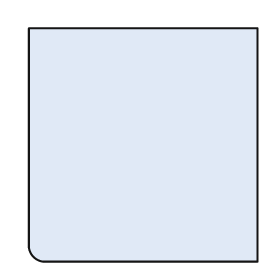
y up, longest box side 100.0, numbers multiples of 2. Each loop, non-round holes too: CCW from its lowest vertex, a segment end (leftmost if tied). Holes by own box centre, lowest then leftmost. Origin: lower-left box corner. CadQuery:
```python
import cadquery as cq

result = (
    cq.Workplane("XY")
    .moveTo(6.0, 0.0)
    .lineTo(98.0, 0.0)
    .lineTo(98.0, 100.0)
    .lineTo(0.0, 100.0)
    .lineTo(0.0, 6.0)
    .threePointArc((2.0, 2.0), (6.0, 0.0))
    .close()
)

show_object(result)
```